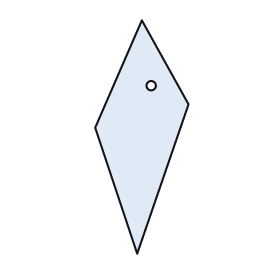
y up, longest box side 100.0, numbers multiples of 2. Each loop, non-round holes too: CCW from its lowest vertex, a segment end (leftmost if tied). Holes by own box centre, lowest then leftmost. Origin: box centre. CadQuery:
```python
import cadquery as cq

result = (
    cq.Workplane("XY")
    .moveTo(-2.0, -50.0)
    .lineTo(20.0, 14.0)
    .lineTo(0.0, 50.0)
    .lineTo(-20.0, 4.0)
    .close()
    .moveTo(4.0, 22.0)
    .circle(2.0)
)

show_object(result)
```